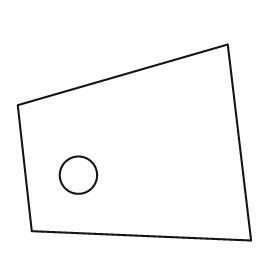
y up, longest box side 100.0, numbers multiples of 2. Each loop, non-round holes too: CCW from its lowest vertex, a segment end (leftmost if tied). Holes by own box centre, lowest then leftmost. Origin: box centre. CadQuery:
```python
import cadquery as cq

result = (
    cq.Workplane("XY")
    .moveTo(50.0, -42.0)
    .lineTo(40.0, 42.0)
    .lineTo(-50.0, 16.0)
    .lineTo(-44.0, -38.0)
    .close()
    .moveTo(-24.0, -14.0)
    .circle(8.0)
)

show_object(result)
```